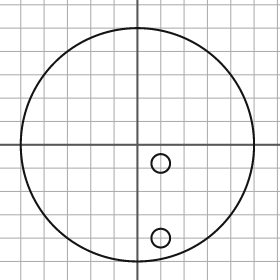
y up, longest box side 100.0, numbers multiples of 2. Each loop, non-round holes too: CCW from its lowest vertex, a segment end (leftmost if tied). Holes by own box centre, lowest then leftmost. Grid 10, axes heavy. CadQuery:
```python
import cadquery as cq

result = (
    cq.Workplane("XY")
    .moveTo(0.0, 0.0)
    .circle(50.0)
    .moveTo(10.0, -40.0)
    .circle(4.0)
    .moveTo(10.0, -8.0)
    .circle(4.0)
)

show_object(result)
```